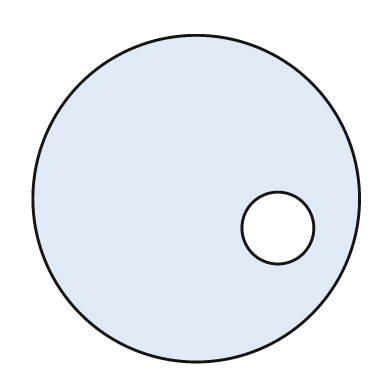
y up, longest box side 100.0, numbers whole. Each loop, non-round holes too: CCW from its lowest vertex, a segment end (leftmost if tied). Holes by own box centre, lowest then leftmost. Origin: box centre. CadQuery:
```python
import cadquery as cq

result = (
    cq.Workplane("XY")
    .moveTo(0.0, 0.0)
    .circle(50.0)
    .moveTo(25.0, -9.0)
    .circle(11.0)
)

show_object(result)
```